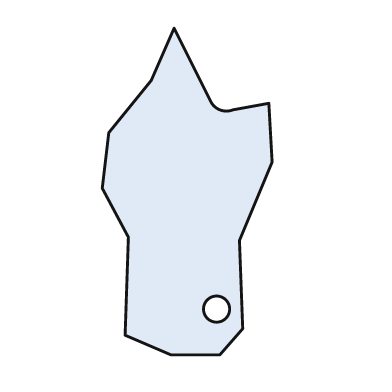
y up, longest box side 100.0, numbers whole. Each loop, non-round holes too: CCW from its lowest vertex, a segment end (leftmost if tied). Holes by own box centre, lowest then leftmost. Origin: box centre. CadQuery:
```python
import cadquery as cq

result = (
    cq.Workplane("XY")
    .moveTo(-5.0, -50.0)
    .lineTo(10.0, -50.0)
    .lineTo(17.0, -42.0)
    .lineTo(16.0, -15.0)
    .lineTo(26.0, 9.0)
    .lineTo(25.0, 27.0)
    .lineTo(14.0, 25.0)
    .threePointArc((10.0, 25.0), (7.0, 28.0))
    .lineTo(-4.0, 50.0)
    .lineTo(-11.0, 34.0)
    .lineTo(-24.0, 18.0)
    .lineTo(-26.0, 1.0)
    .lineTo(-18.0, -14.0)
    .lineTo(-19.0, -44.0)
    .close()
    .moveTo(9.0, -36.0)
    .circle(4.0)
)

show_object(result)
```